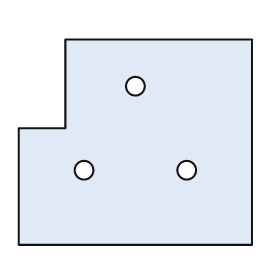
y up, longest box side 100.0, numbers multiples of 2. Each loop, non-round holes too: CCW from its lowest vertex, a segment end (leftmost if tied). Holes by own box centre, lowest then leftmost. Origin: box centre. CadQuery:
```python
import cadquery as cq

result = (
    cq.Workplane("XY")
    .moveTo(-50.0, -44.0)
    .lineTo(50.0, -44.0)
    .lineTo(50.0, 44.0)
    .lineTo(-30.0, 44.0)
    .lineTo(-30.0, 6.0)
    .lineTo(-50.0, 6.0)
    .close()
    .moveTo(-22.0, -12.0)
    .circle(4.0)
    .moveTo(22.0, -12.0)
    .circle(4.0)
    .moveTo(0.0, 24.0)
    .circle(4.0)
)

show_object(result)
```